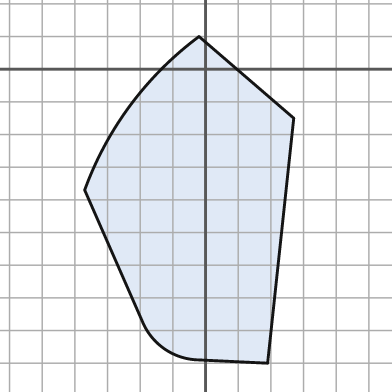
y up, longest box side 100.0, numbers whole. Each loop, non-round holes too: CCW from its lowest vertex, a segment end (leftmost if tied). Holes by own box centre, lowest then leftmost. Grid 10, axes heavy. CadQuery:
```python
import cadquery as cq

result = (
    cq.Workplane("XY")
    .moveTo(19.0, -90.0)
    .lineTo(27.0, -15.0)
    .lineTo(-2.0, 10.0)
    .threePointArc((-23.0, -11.0), (-37.0, -37.0))
    .lineTo(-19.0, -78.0)
    .threePointArc((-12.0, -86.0), (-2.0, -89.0))
    .close()
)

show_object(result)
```